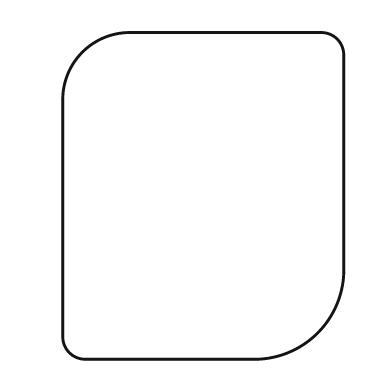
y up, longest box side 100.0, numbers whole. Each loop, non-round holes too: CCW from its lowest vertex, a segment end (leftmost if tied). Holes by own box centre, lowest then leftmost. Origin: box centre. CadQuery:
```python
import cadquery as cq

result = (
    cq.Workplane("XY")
    .moveTo(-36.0, -50.0)
    .lineTo(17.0, -50.0)
    .threePointArc((35.0, -42.0), (43.0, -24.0))
    .lineTo(43.0, 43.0)
    .threePointArc((41.0, 48.0), (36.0, 50.0))
    .lineTo(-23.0, 50.0)
    .threePointArc((-37.0, 44.0), (-43.0, 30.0))
    .lineTo(-43.0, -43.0)
    .threePointArc((-41.0, -48.0), (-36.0, -50.0))
    .close()
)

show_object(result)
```